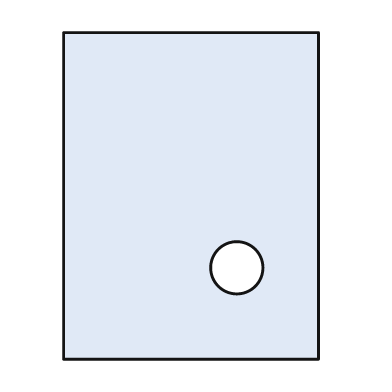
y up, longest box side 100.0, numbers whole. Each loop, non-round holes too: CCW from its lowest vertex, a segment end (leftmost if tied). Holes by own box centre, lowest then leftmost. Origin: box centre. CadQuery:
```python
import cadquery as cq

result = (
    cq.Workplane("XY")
    .moveTo(-39.0, -50.0)
    .lineTo(39.0, -50.0)
    .lineTo(39.0, 50.0)
    .lineTo(-39.0, 50.0)
    .close()
    .moveTo(14.0, -22.0)
    .circle(8.0)
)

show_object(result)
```